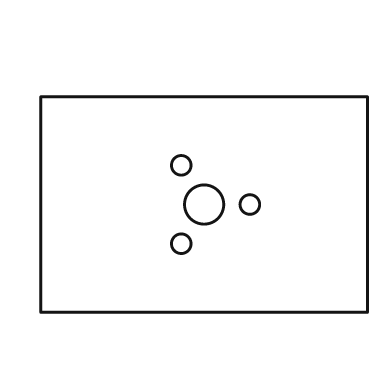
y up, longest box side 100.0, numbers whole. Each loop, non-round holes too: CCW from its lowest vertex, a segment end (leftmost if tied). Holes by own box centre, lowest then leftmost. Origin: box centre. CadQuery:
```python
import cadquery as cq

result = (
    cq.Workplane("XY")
    .moveTo(-50.0, -33.0)
    .lineTo(50.0, -33.0)
    .lineTo(50.0, 33.0)
    .lineTo(-50.0, 33.0)
    .close()
    .moveTo(-7.0, -12.0)
    .circle(3.0)
    .moveTo(0.0, 0.0)
    .circle(6.0)
    .moveTo(14.0, 0.0)
    .circle(3.0)
    .moveTo(-7.0, 12.0)
    .circle(3.0)
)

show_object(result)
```